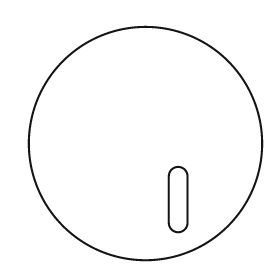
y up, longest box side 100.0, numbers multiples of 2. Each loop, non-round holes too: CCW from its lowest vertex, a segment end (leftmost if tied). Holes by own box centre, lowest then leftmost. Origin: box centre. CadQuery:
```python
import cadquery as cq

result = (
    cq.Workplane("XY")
    .moveTo(0.0, 0.0)
    .circle(50.0)
    .moveTo(10.0, -34.0)
    .threePointArc((14.0, -38.0), (18.0, -34.0))
    .lineTo(18.0, -14.0)
    .threePointArc((14.0, -10.0), (10.0, -14.0))
    .close()
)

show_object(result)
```